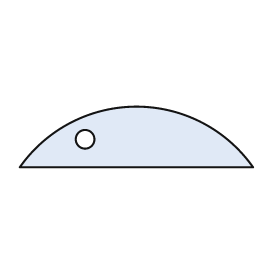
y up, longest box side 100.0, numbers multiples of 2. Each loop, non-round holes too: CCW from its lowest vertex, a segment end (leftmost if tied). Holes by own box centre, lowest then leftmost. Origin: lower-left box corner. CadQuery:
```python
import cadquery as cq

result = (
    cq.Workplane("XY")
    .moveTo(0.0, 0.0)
    .lineTo(100.0, 0.0)
    .threePointArc((50.0, 26.0), (0.0, 0.0))
    .close()
    .moveTo(28.0, 12.0)
    .circle(4.0)
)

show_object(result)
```